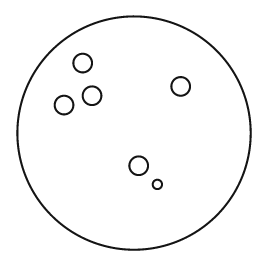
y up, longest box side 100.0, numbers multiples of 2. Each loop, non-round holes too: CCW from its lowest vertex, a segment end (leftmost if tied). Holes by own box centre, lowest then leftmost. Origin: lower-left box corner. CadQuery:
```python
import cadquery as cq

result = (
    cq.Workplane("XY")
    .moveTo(50.0, 50.0)
    .circle(50.0)
    .moveTo(60.0, 28.0)
    .circle(2.0)
    .moveTo(52.0, 36.0)
    .circle(4.0)
    .moveTo(20.0, 62.0)
    .circle(4.0)
    .moveTo(32.0, 66.0)
    .circle(4.0)
    .moveTo(70.0, 70.0)
    .circle(4.0)
    .moveTo(28.0, 80.0)
    .circle(4.0)
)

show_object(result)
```